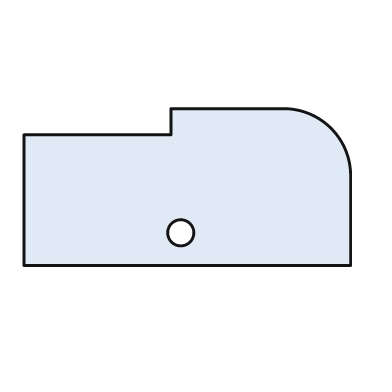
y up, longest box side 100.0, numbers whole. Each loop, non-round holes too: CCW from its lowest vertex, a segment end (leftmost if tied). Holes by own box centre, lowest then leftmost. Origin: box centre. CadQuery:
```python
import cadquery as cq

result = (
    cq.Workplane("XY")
    .moveTo(-50.0, -24.0)
    .lineTo(50.0, -24.0)
    .lineTo(50.0, 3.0)
    .threePointArc((44.0, 18.0), (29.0, 24.0))
    .lineTo(-5.0, 24.0)
    .lineTo(-5.0, 16.0)
    .lineTo(-50.0, 16.0)
    .close()
    .moveTo(-2.0, -14.0)
    .circle(4.0)
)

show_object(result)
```